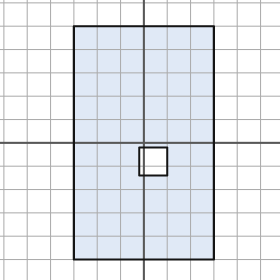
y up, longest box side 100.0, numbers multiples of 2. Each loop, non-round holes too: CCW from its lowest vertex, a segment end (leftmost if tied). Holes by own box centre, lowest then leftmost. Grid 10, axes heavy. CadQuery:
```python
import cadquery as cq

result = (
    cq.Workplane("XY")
    .moveTo(-30.0, -50.0)
    .lineTo(30.0, -50.0)
    .lineTo(30.0, 50.0)
    .lineTo(-30.0, 50.0)
    .close()
    .moveTo(-2.0, -14.0)
    .lineTo(10.0, -14.0)
    .lineTo(10.0, -2.0)
    .lineTo(-2.0, -2.0)
    .close()
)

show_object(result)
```